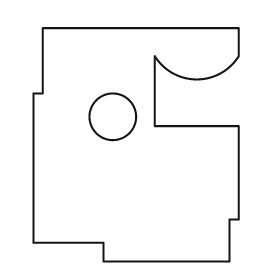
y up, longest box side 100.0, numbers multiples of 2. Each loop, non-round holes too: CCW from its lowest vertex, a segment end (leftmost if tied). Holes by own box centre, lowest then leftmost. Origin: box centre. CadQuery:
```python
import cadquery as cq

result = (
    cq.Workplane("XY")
    .moveTo(-14.0, -50.0)
    .lineTo(40.0, -50.0)
    .lineTo(40.0, -32.0)
    .lineTo(44.0, -32.0)
    .lineTo(44.0, 8.0)
    .lineTo(8.0, 8.0)
    .lineTo(8.0, 38.0)
    .threePointArc((26.0, 28.0), (44.0, 38.0))
    .lineTo(44.0, 50.0)
    .lineTo(-40.0, 50.0)
    .lineTo(-40.0, 22.0)
    .lineTo(-44.0, 22.0)
    .lineTo(-44.0, -42.0)
    .lineTo(-14.0, -42.0)
    .close()
    .moveTo(-10.0, 12.0)
    .circle(10.0)
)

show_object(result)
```